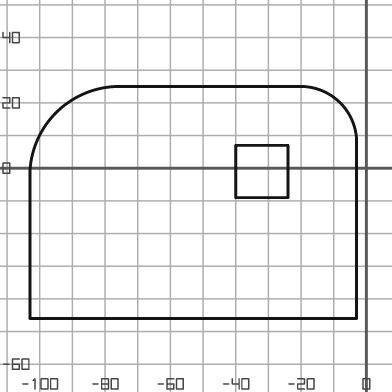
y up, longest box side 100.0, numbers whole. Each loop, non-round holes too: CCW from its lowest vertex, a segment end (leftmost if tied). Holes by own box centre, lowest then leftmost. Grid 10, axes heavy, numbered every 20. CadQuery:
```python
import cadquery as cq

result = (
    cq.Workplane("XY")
    .moveTo(-103.0, -46.0)
    .lineTo(-3.0, -46.0)
    .lineTo(-3.0, 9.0)
    .threePointArc((-8.0, 20.0), (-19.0, 25.0))
    .lineTo(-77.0, 25.0)
    .threePointArc((-95.0, 17.0), (-103.0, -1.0))
    .close()
    .moveTo(-40.0, -9.0)
    .lineTo(-24.0, -9.0)
    .lineTo(-24.0, 7.0)
    .lineTo(-40.0, 7.0)
    .close()
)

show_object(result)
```